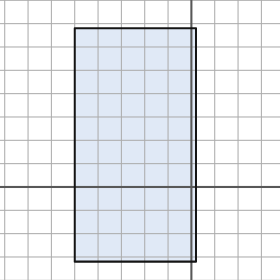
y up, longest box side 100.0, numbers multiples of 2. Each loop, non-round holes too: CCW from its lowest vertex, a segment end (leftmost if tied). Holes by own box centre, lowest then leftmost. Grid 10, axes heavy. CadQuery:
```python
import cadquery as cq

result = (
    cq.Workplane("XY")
    .moveTo(-50.0, -32.0)
    .lineTo(2.0, -32.0)
    .lineTo(2.0, 68.0)
    .lineTo(-50.0, 68.0)
    .close()
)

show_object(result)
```